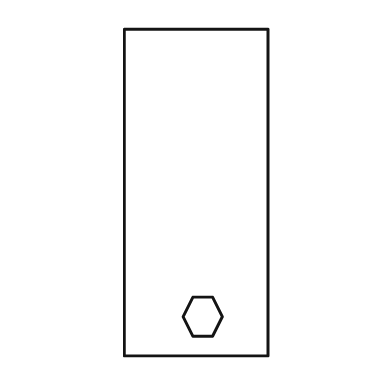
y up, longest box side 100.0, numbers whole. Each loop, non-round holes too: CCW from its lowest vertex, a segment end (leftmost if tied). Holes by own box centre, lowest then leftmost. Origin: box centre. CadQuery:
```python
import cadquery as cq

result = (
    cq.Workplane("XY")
    .moveTo(-22.0, -50.0)
    .lineTo(22.0, -50.0)
    .lineTo(22.0, 50.0)
    .lineTo(-22.0, 50.0)
    .close()
    .moveTo(-1.0, -44.0)
    .lineTo(5.0, -44.0)
    .lineTo(8.0, -38.0)
    .lineTo(5.0, -32.0)
    .lineTo(-1.0, -32.0)
    .lineTo(-4.0, -38.0)
    .close()
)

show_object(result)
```